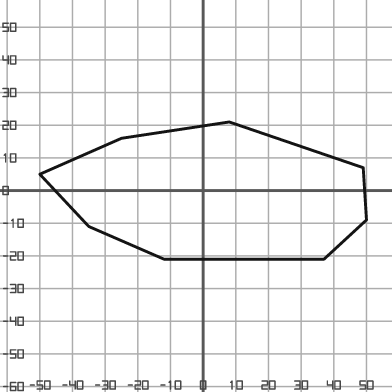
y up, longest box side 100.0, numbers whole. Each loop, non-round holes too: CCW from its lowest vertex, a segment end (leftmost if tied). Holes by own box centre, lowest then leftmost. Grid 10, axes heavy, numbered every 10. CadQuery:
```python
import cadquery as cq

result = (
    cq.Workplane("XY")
    .moveTo(-12.0, -21.0)
    .lineTo(37.0, -21.0)
    .lineTo(50.0, -9.0)
    .lineTo(49.0, 7.0)
    .lineTo(8.0, 21.0)
    .lineTo(-25.0, 16.0)
    .lineTo(-50.0, 5.0)
    .lineTo(-35.0, -11.0)
    .close()
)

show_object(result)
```